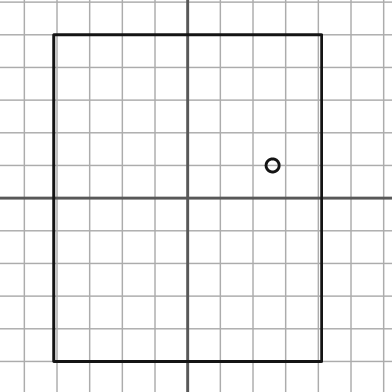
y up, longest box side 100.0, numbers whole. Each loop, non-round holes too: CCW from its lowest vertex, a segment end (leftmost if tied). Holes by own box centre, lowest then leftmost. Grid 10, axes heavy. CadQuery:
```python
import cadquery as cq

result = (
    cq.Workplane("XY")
    .moveTo(-41.0, -50.0)
    .lineTo(41.0, -50.0)
    .lineTo(41.0, 50.0)
    .lineTo(-41.0, 50.0)
    .close()
    .moveTo(26.0, 10.0)
    .circle(2.0)
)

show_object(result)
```